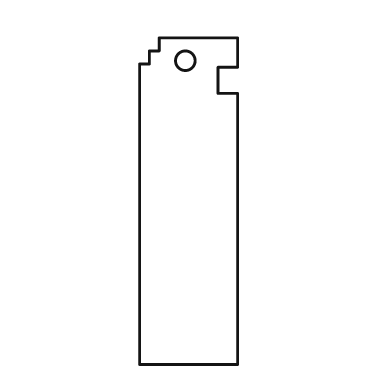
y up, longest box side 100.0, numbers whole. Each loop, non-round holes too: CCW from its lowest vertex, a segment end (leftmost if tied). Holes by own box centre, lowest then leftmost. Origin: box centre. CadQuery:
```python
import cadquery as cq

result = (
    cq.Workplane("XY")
    .moveTo(-15.0, -50.0)
    .lineTo(15.0, -50.0)
    .lineTo(15.0, 33.0)
    .lineTo(9.0, 33.0)
    .lineTo(9.0, 41.0)
    .lineTo(15.0, 41.0)
    .lineTo(15.0, 50.0)
    .lineTo(-9.0, 50.0)
    .lineTo(-9.0, 46.0)
    .lineTo(-12.0, 46.0)
    .lineTo(-12.0, 42.0)
    .lineTo(-15.0, 42.0)
    .close()
    .moveTo(-1.0, 43.0)
    .circle(3.0)
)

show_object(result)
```